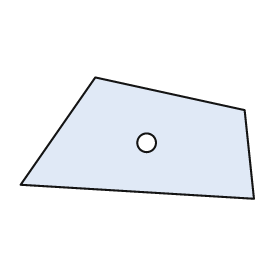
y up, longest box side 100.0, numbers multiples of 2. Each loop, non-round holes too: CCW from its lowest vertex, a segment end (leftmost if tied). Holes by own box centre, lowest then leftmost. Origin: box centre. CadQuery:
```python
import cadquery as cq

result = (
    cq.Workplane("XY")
    .moveTo(50.0, -26.0)
    .lineTo(46.0, 12.0)
    .lineTo(-18.0, 26.0)
    .lineTo(-50.0, -20.0)
    .close()
    .moveTo(4.0, -2.0)
    .circle(4.0)
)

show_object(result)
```